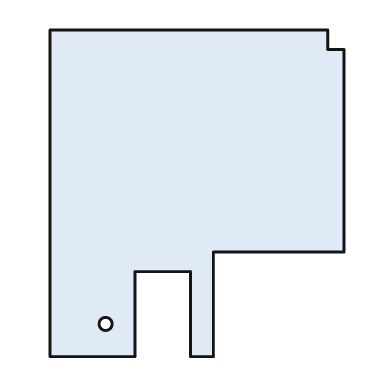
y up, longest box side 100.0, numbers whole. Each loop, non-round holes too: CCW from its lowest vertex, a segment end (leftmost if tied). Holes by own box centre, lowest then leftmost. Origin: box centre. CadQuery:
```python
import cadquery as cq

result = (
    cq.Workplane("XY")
    .moveTo(-45.0, -50.0)
    .lineTo(-19.0, -50.0)
    .lineTo(-19.0, -24.0)
    .lineTo(-2.0, -24.0)
    .lineTo(-2.0, -50.0)
    .lineTo(5.0, -50.0)
    .lineTo(5.0, -18.0)
    .lineTo(45.0, -18.0)
    .lineTo(45.0, 44.0)
    .lineTo(40.0, 44.0)
    .lineTo(40.0, 50.0)
    .lineTo(-45.0, 50.0)
    .close()
    .moveTo(-28.0, -40.0)
    .circle(2.0)
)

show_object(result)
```